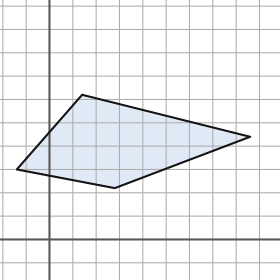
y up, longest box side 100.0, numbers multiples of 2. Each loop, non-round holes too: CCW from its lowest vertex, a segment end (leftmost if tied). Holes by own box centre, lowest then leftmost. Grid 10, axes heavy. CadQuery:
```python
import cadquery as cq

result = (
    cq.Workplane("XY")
    .moveTo(28.0, 22.0)
    .lineTo(86.0, 44.0)
    .lineTo(14.0, 62.0)
    .lineTo(-14.0, 30.0)
    .close()
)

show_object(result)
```